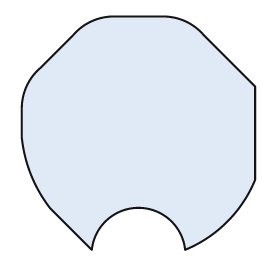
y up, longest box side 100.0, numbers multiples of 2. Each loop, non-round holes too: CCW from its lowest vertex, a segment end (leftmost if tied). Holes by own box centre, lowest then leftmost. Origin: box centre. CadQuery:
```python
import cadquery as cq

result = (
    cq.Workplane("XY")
    .moveTo(-20.0, -50.0)
    .threePointArc((0.0, -32.0), (20.0, -50.0))
    .threePointArc((38.0, -38.0), (50.0, -20.0))
    .lineTo(50.0, 20.0)
    .lineTo(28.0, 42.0)
    .threePointArc((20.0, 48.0), (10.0, 50.0))
    .lineTo(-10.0, 50.0)
    .threePointArc((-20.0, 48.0), (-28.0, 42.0))
    .lineTo(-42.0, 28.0)
    .threePointArc((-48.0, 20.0), (-50.0, 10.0))
    .lineTo(-50.0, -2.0)
    .threePointArc((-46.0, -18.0), (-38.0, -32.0))
    .close()
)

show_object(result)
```